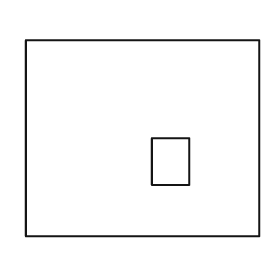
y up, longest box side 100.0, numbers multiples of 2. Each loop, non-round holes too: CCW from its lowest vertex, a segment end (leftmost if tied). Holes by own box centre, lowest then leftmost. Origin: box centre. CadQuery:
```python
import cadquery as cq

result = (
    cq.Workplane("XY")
    .moveTo(-50.0, -42.0)
    .lineTo(50.0, -42.0)
    .lineTo(50.0, 42.0)
    .lineTo(-50.0, 42.0)
    .close()
    .moveTo(4.0, -20.0)
    .lineTo(20.0, -20.0)
    .lineTo(20.0, 0.0)
    .lineTo(4.0, 0.0)
    .close()
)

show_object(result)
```